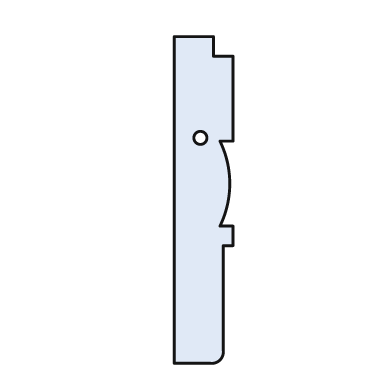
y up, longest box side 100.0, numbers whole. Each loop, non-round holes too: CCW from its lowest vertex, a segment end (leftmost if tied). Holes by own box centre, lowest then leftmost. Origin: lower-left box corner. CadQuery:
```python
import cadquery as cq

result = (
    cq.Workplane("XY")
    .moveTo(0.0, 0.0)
    .lineTo(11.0, 0.0)
    .threePointArc((14.0, 1.0), (15.0, 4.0))
    .lineTo(15.0, 36.0)
    .lineTo(18.0, 36.0)
    .lineTo(18.0, 42.0)
    .lineTo(14.0, 42.0)
    .threePointArc((17.0, 55.0), (14.0, 68.0))
    .lineTo(18.0, 68.0)
    .lineTo(18.0, 94.0)
    .lineTo(12.0, 94.0)
    .lineTo(12.0, 100.0)
    .lineTo(0.0, 100.0)
    .close()
    .moveTo(8.0, 69.0)
    .circle(2.0)
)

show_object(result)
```